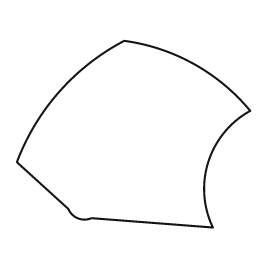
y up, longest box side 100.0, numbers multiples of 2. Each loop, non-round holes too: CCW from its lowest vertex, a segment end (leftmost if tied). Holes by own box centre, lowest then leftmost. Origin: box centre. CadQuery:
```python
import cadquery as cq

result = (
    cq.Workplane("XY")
    .moveTo(34.0, -40.0)
    .threePointArc((32.0, -12.0), (50.0, 10.0))
    .threePointArc((26.0, 30.0), (-4.0, 40.0))
    .threePointArc((-32.0, 18.0), (-50.0, -12.0))
    .lineTo(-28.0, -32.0)
    .threePointArc((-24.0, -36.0), (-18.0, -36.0))
    .close()
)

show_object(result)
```